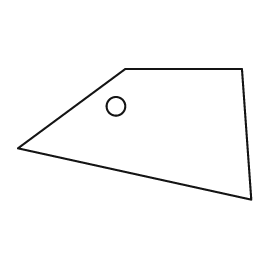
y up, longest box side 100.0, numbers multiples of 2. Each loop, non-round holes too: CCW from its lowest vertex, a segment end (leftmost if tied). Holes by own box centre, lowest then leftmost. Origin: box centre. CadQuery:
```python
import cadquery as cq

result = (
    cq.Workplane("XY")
    .moveTo(50.0, -28.0)
    .lineTo(46.0, 28.0)
    .lineTo(-4.0, 28.0)
    .lineTo(-50.0, -6.0)
    .close()
    .moveTo(-8.0, 12.0)
    .circle(4.0)
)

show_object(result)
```